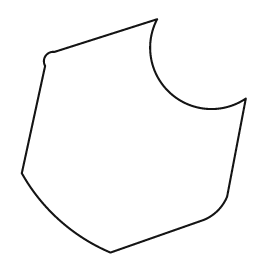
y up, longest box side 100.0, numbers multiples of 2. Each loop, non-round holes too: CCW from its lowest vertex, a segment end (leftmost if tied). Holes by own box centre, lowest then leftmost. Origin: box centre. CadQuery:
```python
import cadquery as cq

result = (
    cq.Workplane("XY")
    .moveTo(-10.0, -50.0)
    .lineTo(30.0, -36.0)
    .threePointArc((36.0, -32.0), (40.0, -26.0))
    .lineTo(48.0, 16.0)
    .threePointArc((16.0, 18.0), (10.0, 50.0))
    .lineTo(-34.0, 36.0)
    .threePointArc((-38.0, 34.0), (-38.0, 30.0))
    .lineTo(-48.0, -16.0)
    .threePointArc((-32.0, -36.0), (-10.0, -50.0))
    .close()
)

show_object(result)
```